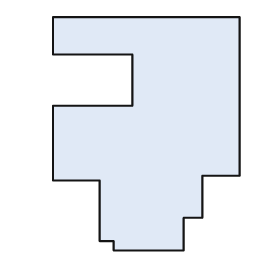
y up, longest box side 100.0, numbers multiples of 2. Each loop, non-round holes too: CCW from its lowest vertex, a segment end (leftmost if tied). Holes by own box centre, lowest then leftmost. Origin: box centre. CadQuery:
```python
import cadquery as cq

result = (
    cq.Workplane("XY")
    .moveTo(-14.0, -50.0)
    .lineTo(16.0, -50.0)
    .lineTo(16.0, -36.0)
    .lineTo(24.0, -36.0)
    .lineTo(24.0, -18.0)
    .lineTo(40.0, -18.0)
    .lineTo(40.0, 50.0)
    .lineTo(-40.0, 50.0)
    .lineTo(-40.0, 34.0)
    .lineTo(-6.0, 34.0)
    .lineTo(-6.0, 12.0)
    .lineTo(-40.0, 12.0)
    .lineTo(-40.0, -20.0)
    .lineTo(-20.0, -20.0)
    .lineTo(-20.0, -46.0)
    .lineTo(-14.0, -46.0)
    .close()
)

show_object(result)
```